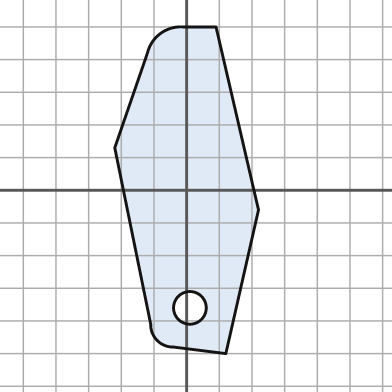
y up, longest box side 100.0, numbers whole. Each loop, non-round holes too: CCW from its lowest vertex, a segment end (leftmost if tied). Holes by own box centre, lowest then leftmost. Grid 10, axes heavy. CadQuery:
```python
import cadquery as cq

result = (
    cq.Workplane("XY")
    .moveTo(12.0, -50.0)
    .lineTo(22.0, -6.0)
    .lineTo(9.0, 50.0)
    .lineTo(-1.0, 50.0)
    .threePointArc((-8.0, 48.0), (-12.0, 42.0))
    .lineTo(-22.0, 13.0)
    .lineTo(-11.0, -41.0)
    .threePointArc((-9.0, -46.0), (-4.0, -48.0))
    .close()
    .moveTo(1.0, -36.0)
    .circle(5.0)
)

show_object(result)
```